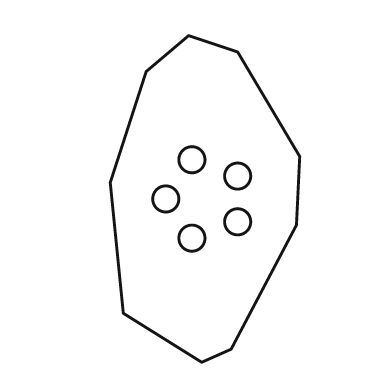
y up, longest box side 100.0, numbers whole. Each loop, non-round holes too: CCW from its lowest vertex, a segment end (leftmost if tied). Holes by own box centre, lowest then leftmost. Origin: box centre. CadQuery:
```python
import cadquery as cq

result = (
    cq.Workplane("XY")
    .moveTo(-1.0, -50.0)
    .lineTo(8.0, -46.0)
    .lineTo(28.0, -8.0)
    .lineTo(29.0, 13.0)
    .lineTo(10.0, 45.0)
    .lineTo(-5.0, 50.0)
    .lineTo(-18.0, 39.0)
    .lineTo(-29.0, 5.0)
    .lineTo(-25.0, -35.0)
    .close()
    .moveTo(-4.0, -12.0)
    .circle(4.0)
    .moveTo(10.0, -7.0)
    .circle(4.0)
    .moveTo(-12.0, 0.0)
    .circle(4.0)
    .moveTo(10.0, 7.0)
    .circle(4.0)
    .moveTo(-4.0, 12.0)
    .circle(4.0)
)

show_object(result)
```